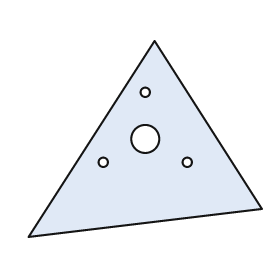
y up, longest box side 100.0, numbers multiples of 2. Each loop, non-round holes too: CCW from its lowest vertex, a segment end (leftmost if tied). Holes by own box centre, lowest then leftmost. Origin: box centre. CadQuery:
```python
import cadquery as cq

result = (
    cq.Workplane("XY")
    .moveTo(-50.0, -42.0)
    .lineTo(50.0, -30.0)
    .lineTo(4.0, 42.0)
    .close()
    .moveTo(-18.0, -10.0)
    .circle(2.0)
    .moveTo(18.0, -10.0)
    .circle(2.0)
    .moveTo(0.0, 0.0)
    .circle(6.0)
    .moveTo(0.0, 20.0)
    .circle(2.0)
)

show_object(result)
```